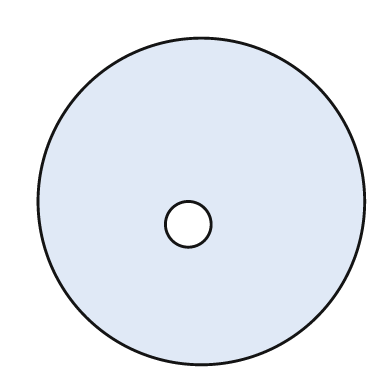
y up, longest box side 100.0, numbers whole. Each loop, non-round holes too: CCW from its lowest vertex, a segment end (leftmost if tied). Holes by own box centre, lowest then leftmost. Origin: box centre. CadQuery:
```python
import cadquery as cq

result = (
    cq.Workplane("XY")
    .moveTo(0.0, 0.0)
    .circle(50.0)
    .moveTo(-4.0, -7.0)
    .circle(7.0)
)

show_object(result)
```